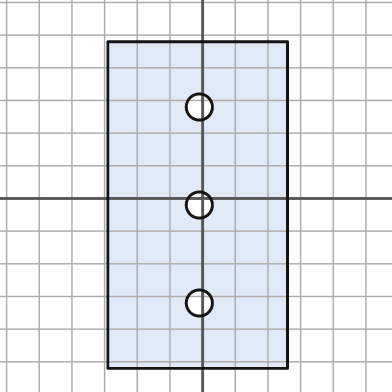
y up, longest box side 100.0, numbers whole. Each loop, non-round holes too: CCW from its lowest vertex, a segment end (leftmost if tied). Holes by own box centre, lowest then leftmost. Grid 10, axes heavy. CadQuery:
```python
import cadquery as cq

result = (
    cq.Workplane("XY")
    .moveTo(-29.0, -52.0)
    .lineTo(26.0, -52.0)
    .lineTo(26.0, 48.0)
    .lineTo(-29.0, 48.0)
    .close()
    .moveTo(-1.0, -32.0)
    .circle(4.0)
    .moveTo(-1.0, -2.0)
    .circle(4.0)
    .moveTo(-1.0, 28.0)
    .circle(4.0)
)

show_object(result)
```